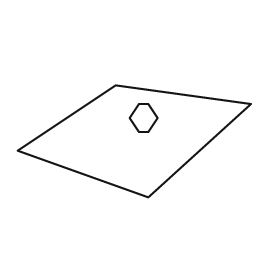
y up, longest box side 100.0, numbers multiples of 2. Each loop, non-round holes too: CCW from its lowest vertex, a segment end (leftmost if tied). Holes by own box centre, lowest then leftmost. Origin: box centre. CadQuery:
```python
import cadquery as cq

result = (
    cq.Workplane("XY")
    .moveTo(6.0, -24.0)
    .lineTo(50.0, 16.0)
    .lineTo(-8.0, 24.0)
    .lineTo(-50.0, -4.0)
    .close()
    .moveTo(2.0, 4.0)
    .lineTo(6.0, 4.0)
    .lineTo(10.0, 10.0)
    .lineTo(6.0, 16.0)
    .lineTo(2.0, 16.0)
    .lineTo(-2.0, 10.0)
    .close()
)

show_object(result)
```